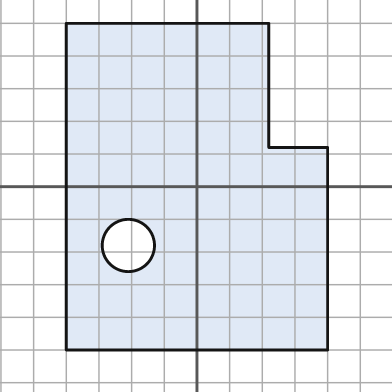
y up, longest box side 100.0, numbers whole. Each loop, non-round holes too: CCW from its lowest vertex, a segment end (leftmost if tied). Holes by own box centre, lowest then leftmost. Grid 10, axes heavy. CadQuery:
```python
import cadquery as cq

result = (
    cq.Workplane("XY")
    .moveTo(-40.0, -50.0)
    .lineTo(40.0, -50.0)
    .lineTo(40.0, 12.0)
    .lineTo(22.0, 12.0)
    .lineTo(22.0, 50.0)
    .lineTo(-40.0, 50.0)
    .close()
    .moveTo(-21.0, -18.0)
    .circle(8.0)
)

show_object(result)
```